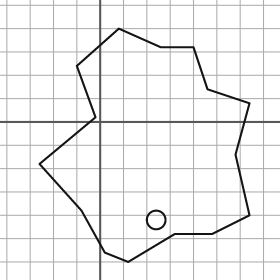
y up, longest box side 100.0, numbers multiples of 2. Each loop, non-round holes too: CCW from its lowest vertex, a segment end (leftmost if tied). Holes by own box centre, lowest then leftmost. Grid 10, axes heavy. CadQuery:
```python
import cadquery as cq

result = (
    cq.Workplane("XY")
    .moveTo(12.0, -60.0)
    .lineTo(32.0, -48.0)
    .lineTo(48.0, -48.0)
    .lineTo(64.0, -40.0)
    .lineTo(58.0, -14.0)
    .lineTo(64.0, 8.0)
    .lineTo(46.0, 14.0)
    .lineTo(40.0, 32.0)
    .lineTo(26.0, 32.0)
    .lineTo(8.0, 40.0)
    .lineTo(-10.0, 24.0)
    .lineTo(-2.0, 2.0)
    .lineTo(-26.0, -18.0)
    .lineTo(-8.0, -38.0)
    .lineTo(2.0, -56.0)
    .close()
    .moveTo(24.0, -42.0)
    .circle(4.0)
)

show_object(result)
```